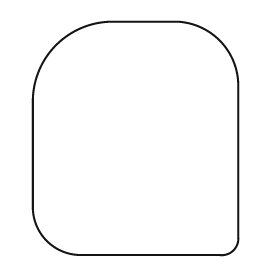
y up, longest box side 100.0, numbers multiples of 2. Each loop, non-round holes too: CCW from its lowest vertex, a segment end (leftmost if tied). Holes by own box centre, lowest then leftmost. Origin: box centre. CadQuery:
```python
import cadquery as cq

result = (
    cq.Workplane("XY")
    .moveTo(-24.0, -50.0)
    .lineTo(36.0, -50.0)
    .threePointArc((42.0, -48.0), (44.0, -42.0))
    .lineTo(44.0, 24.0)
    .threePointArc((36.0, 42.0), (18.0, 50.0))
    .lineTo(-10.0, 50.0)
    .threePointArc((-34.0, 40.0), (-44.0, 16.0))
    .lineTo(-44.0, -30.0)
    .threePointArc((-38.0, -44.0), (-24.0, -50.0))
    .close()
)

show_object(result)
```